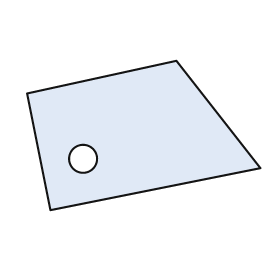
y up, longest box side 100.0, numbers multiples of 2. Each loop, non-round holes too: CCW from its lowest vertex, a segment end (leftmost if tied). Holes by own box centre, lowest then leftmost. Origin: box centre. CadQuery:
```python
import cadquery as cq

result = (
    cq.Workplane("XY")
    .moveTo(-40.0, -32.0)
    .lineTo(50.0, -14.0)
    .lineTo(14.0, 32.0)
    .lineTo(-50.0, 18.0)
    .close()
    .moveTo(-26.0, -10.0)
    .circle(6.0)
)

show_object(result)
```